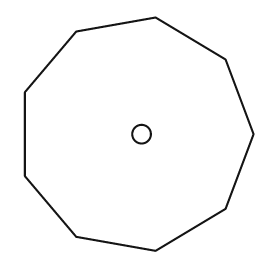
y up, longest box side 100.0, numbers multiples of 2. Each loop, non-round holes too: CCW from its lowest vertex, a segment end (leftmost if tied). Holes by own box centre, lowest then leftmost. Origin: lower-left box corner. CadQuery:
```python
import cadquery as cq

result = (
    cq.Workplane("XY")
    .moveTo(56.0, 0.0)
    .lineTo(86.0, 18.0)
    .lineTo(98.0, 50.0)
    .lineTo(86.0, 82.0)
    .lineTo(56.0, 100.0)
    .lineTo(22.0, 94.0)
    .lineTo(0.0, 68.0)
    .lineTo(0.0, 32.0)
    .lineTo(22.0, 6.0)
    .close()
    .moveTo(50.0, 50.0)
    .circle(4.0)
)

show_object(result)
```